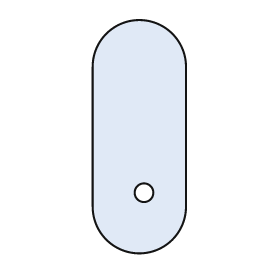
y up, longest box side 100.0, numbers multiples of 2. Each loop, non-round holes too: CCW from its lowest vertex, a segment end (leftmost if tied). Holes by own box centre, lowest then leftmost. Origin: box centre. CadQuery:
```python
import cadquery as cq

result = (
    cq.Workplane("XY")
    .moveTo(-20.0, -30.0)
    .threePointArc((0.0, -50.0), (20.0, -30.0))
    .lineTo(20.0, 30.0)
    .threePointArc((0.0, 50.0), (-20.0, 30.0))
    .close()
    .moveTo(2.0, -24.0)
    .circle(4.0)
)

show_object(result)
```